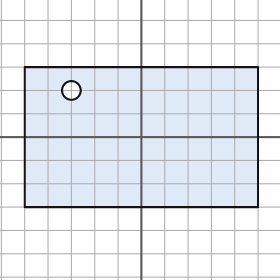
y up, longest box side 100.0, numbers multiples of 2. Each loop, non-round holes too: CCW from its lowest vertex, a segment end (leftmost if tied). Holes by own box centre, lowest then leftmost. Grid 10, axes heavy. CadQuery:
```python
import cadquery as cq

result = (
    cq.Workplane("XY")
    .moveTo(-50.0, -30.0)
    .lineTo(50.0, -30.0)
    .lineTo(50.0, 30.0)
    .lineTo(-50.0, 30.0)
    .close()
    .moveTo(-30.0, 20.0)
    .circle(4.0)
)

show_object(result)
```